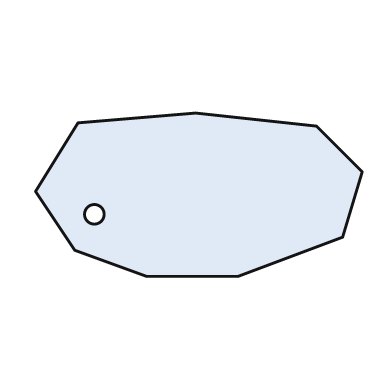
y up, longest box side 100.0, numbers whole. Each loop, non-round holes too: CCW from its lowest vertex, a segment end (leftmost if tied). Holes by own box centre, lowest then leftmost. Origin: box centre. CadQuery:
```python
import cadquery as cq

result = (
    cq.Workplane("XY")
    .moveTo(-16.0, -25.0)
    .lineTo(12.0, -25.0)
    .lineTo(44.0, -13.0)
    .lineTo(50.0, 7.0)
    .lineTo(36.0, 21.0)
    .lineTo(-1.0, 25.0)
    .lineTo(-37.0, 22.0)
    .lineTo(-50.0, 1.0)
    .lineTo(-38.0, -17.0)
    .close()
    .moveTo(-32.0, -6.0)
    .circle(3.0)
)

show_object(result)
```